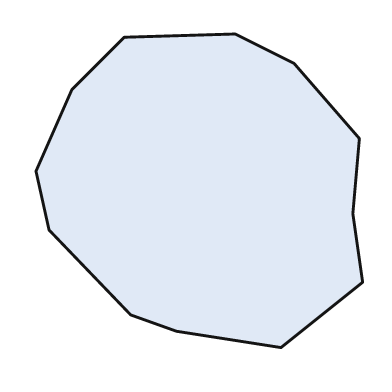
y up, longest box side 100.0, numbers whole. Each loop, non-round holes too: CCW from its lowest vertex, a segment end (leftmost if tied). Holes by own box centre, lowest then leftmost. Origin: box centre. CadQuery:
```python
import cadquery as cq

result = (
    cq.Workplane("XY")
    .moveTo(25.0, -48.0)
    .lineTo(50.0, -28.0)
    .lineTo(47.0, -7.0)
    .lineTo(49.0, 16.0)
    .lineTo(29.0, 39.0)
    .lineTo(11.0, 48.0)
    .lineTo(-23.0, 47.0)
    .lineTo(-39.0, 31.0)
    .lineTo(-50.0, 6.0)
    .lineTo(-46.0, -12.0)
    .lineTo(-21.0, -38.0)
    .lineTo(-7.0, -43.0)
    .close()
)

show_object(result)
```